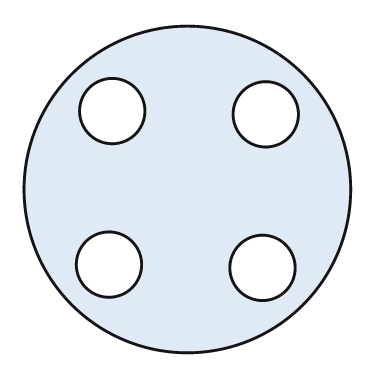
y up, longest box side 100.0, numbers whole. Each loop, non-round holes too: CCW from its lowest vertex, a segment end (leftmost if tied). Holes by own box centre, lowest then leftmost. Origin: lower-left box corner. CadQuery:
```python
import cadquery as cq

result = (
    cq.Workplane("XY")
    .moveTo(50.0, 50.0)
    .circle(50.0)
    .moveTo(73.0, 26.0)
    .circle(10.0)
    .moveTo(26.0, 27.0)
    .circle(10.0)
    .moveTo(74.0, 73.0)
    .circle(10.0)
    .moveTo(27.0, 74.0)
    .circle(10.0)
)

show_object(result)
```